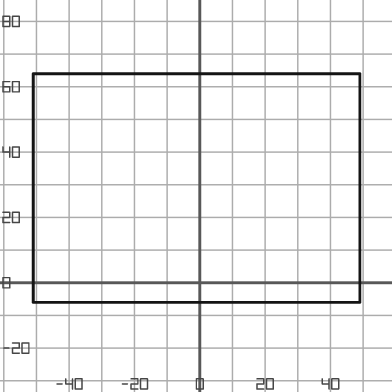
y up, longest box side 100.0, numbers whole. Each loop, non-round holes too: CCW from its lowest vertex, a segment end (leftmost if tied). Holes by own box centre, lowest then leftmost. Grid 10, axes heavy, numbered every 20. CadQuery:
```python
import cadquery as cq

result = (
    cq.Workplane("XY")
    .moveTo(-51.0, -6.0)
    .lineTo(49.0, -6.0)
    .lineTo(49.0, 64.0)
    .lineTo(-51.0, 64.0)
    .close()
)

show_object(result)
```